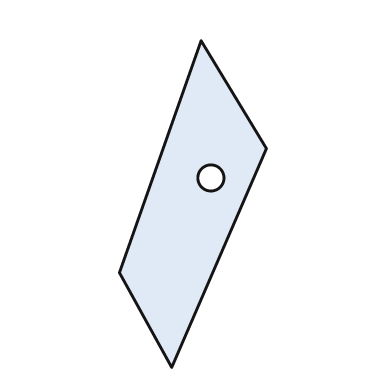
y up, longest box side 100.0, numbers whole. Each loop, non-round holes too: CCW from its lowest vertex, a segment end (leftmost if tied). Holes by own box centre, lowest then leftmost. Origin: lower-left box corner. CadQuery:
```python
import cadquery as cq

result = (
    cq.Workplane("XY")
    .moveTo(16.0, 0.0)
    .lineTo(45.0, 67.0)
    .lineTo(25.0, 100.0)
    .lineTo(0.0, 29.0)
    .close()
    .moveTo(28.0, 58.0)
    .circle(4.0)
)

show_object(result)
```